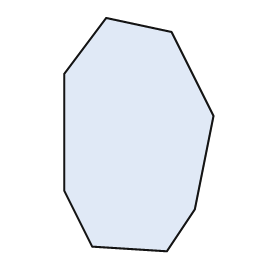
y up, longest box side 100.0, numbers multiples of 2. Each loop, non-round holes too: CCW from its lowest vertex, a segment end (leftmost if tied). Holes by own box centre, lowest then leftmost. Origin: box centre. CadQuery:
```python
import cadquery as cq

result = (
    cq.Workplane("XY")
    .moveTo(12.0, -50.0)
    .lineTo(24.0, -32.0)
    .lineTo(32.0, 8.0)
    .lineTo(14.0, 44.0)
    .lineTo(-14.0, 50.0)
    .lineTo(-32.0, 26.0)
    .lineTo(-32.0, -24.0)
    .lineTo(-20.0, -48.0)
    .close()
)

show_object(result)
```